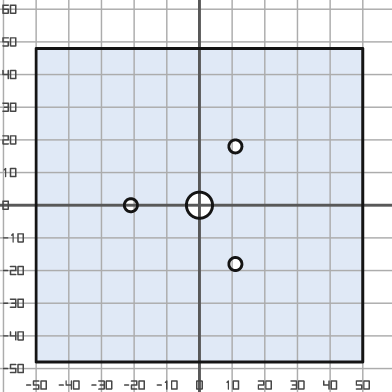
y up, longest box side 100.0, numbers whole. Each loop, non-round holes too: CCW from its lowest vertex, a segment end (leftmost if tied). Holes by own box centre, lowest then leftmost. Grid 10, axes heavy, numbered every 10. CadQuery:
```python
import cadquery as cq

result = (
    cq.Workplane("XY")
    .moveTo(-50.0, -48.0)
    .lineTo(50.0, -48.0)
    .lineTo(50.0, 48.0)
    .lineTo(-50.0, 48.0)
    .close()
    .moveTo(11.0, -18.0)
    .circle(2.0)
    .moveTo(-21.0, 0.0)
    .circle(2.0)
    .moveTo(0.0, 0.0)
    .circle(4.0)
    .moveTo(11.0, 18.0)
    .circle(2.0)
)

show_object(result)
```